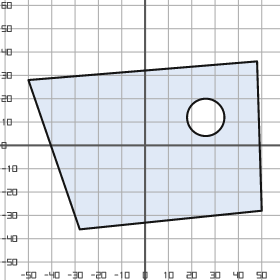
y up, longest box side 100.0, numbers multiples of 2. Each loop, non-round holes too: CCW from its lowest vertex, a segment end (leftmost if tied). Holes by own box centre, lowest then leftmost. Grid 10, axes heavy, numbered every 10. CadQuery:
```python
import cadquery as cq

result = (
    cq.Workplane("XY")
    .moveTo(-28.0, -36.0)
    .lineTo(50.0, -28.0)
    .lineTo(48.0, 36.0)
    .lineTo(-50.0, 28.0)
    .close()
    .moveTo(26.0, 12.0)
    .circle(8.0)
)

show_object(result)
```